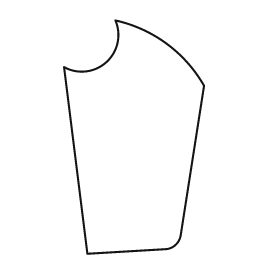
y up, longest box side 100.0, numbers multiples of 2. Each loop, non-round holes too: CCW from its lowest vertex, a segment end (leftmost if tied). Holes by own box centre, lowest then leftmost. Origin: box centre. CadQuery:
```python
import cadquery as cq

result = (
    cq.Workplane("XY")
    .moveTo(-20.0, -50.0)
    .lineTo(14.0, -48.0)
    .threePointArc((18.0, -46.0), (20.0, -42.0))
    .lineTo(30.0, 22.0)
    .threePointArc((14.0, 40.0), (-8.0, 50.0))
    .threePointArc((-12.0, 32.0), (-30.0, 30.0))
    .close()
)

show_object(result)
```